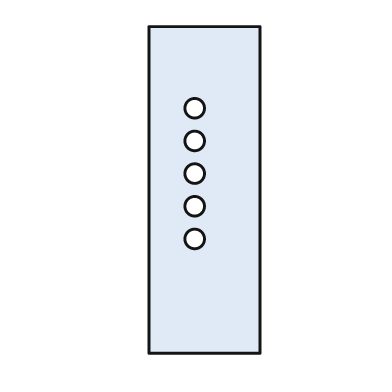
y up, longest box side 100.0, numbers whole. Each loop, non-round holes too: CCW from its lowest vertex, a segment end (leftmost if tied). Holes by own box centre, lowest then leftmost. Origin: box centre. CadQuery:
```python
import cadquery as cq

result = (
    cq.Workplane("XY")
    .moveTo(-17.0, -50.0)
    .lineTo(17.0, -50.0)
    .lineTo(17.0, 50.0)
    .lineTo(-17.0, 50.0)
    .close()
    .moveTo(-3.0, -15.0)
    .circle(3.0)
    .moveTo(-3.0, -5.0)
    .circle(3.0)
    .moveTo(-3.0, 5.0)
    .circle(3.0)
    .moveTo(-3.0, 15.0)
    .circle(3.0)
    .moveTo(-3.0, 25.0)
    .circle(3.0)
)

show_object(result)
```